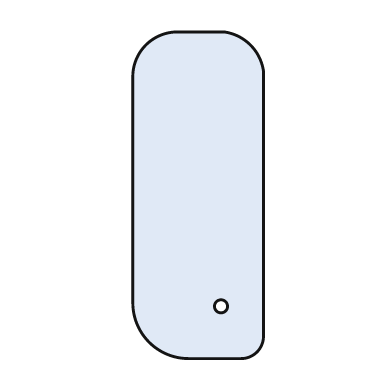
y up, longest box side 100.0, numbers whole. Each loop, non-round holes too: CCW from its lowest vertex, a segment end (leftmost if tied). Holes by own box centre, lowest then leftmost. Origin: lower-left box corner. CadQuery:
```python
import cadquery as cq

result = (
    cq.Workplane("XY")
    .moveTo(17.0, 0.0)
    .lineTo(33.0, 0.0)
    .threePointArc((38.0, 2.0), (40.0, 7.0))
    .lineTo(40.0, 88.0)
    .threePointArc((36.0, 96.0), (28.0, 100.0))
    .lineTo(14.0, 100.0)
    .threePointArc((4.0, 96.0), (0.0, 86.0))
    .lineTo(0.0, 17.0)
    .threePointArc((5.0, 5.0), (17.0, 0.0))
    .close()
    .moveTo(27.0, 16.0)
    .circle(2.0)
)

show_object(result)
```